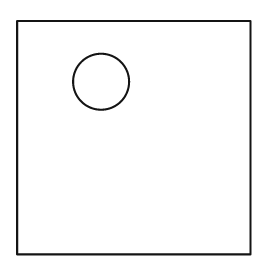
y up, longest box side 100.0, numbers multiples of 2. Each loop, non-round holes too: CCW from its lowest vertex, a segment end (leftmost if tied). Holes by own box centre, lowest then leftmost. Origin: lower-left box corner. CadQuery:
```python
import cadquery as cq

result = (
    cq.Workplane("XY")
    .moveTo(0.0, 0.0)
    .lineTo(100.0, 0.0)
    .lineTo(100.0, 100.0)
    .lineTo(0.0, 100.0)
    .close()
    .moveTo(36.0, 74.0)
    .circle(12.0)
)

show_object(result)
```